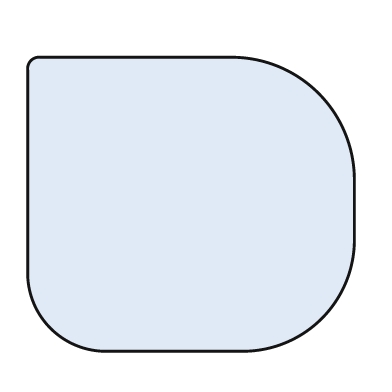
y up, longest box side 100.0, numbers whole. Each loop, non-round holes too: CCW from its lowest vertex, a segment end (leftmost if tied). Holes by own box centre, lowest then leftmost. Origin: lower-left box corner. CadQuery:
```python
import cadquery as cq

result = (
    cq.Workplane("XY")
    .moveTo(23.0, 0.0)
    .lineTo(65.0, 0.0)
    .threePointArc((90.0, 10.0), (100.0, 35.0))
    .lineTo(100.0, 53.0)
    .threePointArc((89.0, 79.0), (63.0, 90.0))
    .lineTo(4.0, 90.0)
    .threePointArc((1.0, 89.0), (0.0, 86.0))
    .lineTo(0.0, 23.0)
    .threePointArc((7.0, 7.0), (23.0, 0.0))
    .close()
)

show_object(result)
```